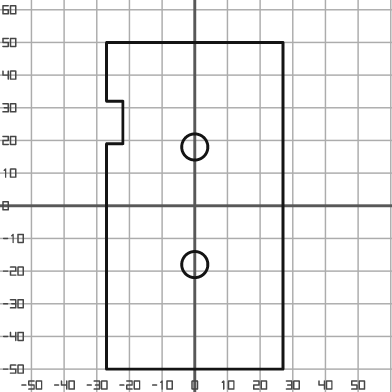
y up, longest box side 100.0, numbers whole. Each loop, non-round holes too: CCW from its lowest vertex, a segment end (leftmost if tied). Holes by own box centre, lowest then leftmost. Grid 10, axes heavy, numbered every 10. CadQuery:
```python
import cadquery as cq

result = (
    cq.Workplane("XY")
    .moveTo(-27.0, -50.0)
    .lineTo(27.0, -50.0)
    .lineTo(27.0, 50.0)
    .lineTo(-27.0, 50.0)
    .lineTo(-27.0, 32.0)
    .lineTo(-22.0, 32.0)
    .lineTo(-22.0, 19.0)
    .lineTo(-27.0, 19.0)
    .close()
    .moveTo(0.0, -18.0)
    .circle(4.0)
    .moveTo(0.0, 18.0)
    .circle(4.0)
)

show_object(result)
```